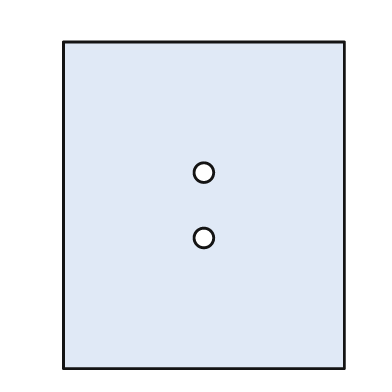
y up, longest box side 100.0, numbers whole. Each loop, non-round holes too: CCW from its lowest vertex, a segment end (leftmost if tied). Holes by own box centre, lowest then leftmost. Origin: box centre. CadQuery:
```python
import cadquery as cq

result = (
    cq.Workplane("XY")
    .moveTo(-43.0, -50.0)
    .lineTo(43.0, -50.0)
    .lineTo(43.0, 50.0)
    .lineTo(-43.0, 50.0)
    .close()
    .moveTo(0.0, -10.0)
    .circle(3.0)
    .moveTo(0.0, 10.0)
    .circle(3.0)
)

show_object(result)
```